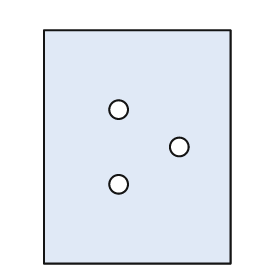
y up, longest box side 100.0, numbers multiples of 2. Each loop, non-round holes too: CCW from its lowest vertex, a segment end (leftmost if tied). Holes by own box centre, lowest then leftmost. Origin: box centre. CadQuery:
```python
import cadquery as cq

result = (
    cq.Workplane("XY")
    .moveTo(-40.0, -50.0)
    .lineTo(40.0, -50.0)
    .lineTo(40.0, 50.0)
    .lineTo(-40.0, 50.0)
    .close()
    .moveTo(-8.0, -16.0)
    .circle(4.0)
    .moveTo(18.0, 0.0)
    .circle(4.0)
    .moveTo(-8.0, 16.0)
    .circle(4.0)
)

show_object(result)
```